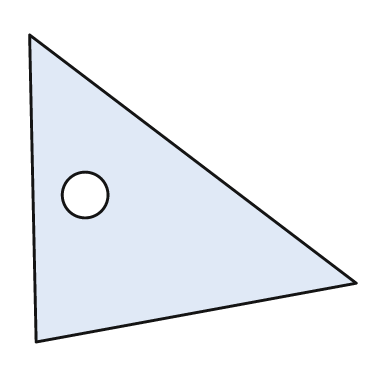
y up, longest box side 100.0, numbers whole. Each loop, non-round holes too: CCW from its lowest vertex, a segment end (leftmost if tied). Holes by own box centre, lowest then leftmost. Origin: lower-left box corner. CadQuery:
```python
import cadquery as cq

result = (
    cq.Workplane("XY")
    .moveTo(2.0, 0.0)
    .lineTo(100.0, 18.0)
    .lineTo(0.0, 94.0)
    .close()
    .moveTo(17.0, 45.0)
    .circle(7.0)
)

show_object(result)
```